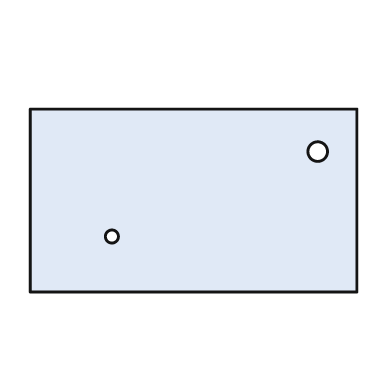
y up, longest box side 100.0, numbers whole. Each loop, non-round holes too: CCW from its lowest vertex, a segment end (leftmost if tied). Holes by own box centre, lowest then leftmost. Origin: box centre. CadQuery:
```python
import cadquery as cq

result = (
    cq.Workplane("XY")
    .moveTo(-50.0, -28.0)
    .lineTo(50.0, -28.0)
    .lineTo(50.0, 28.0)
    .lineTo(-50.0, 28.0)
    .close()
    .moveTo(-25.0, -11.0)
    .circle(2.0)
    .moveTo(38.0, 15.0)
    .circle(3.0)
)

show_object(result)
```